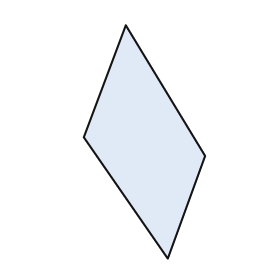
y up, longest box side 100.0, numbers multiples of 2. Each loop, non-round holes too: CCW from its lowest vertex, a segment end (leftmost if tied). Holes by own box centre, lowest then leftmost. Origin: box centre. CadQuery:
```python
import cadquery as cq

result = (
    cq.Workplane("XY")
    .moveTo(10.0, -50.0)
    .lineTo(26.0, -6.0)
    .lineTo(-8.0, 50.0)
    .lineTo(-26.0, 2.0)
    .close()
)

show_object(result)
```